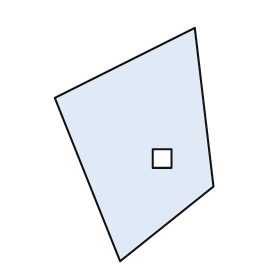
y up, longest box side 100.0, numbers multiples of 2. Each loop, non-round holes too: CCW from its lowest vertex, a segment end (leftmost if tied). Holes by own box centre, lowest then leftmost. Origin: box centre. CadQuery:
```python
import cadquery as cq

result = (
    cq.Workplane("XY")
    .moveTo(-6.0, -50.0)
    .lineTo(34.0, -18.0)
    .lineTo(26.0, 50.0)
    .lineTo(-34.0, 20.0)
    .close()
    .moveTo(8.0, -10.0)
    .lineTo(16.0, -10.0)
    .lineTo(16.0, -2.0)
    .lineTo(8.0, -2.0)
    .close()
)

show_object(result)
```